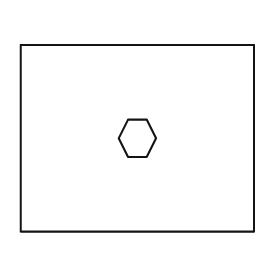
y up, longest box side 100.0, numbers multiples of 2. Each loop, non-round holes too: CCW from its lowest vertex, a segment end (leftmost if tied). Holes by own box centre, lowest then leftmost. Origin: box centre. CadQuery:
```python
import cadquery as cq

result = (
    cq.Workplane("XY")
    .moveTo(-50.0, -40.0)
    .lineTo(50.0, -40.0)
    .lineTo(50.0, 40.0)
    .lineTo(-50.0, 40.0)
    .close()
    .moveTo(-4.0, -8.0)
    .lineTo(4.0, -8.0)
    .lineTo(8.0, 0.0)
    .lineTo(4.0, 8.0)
    .lineTo(-4.0, 8.0)
    .lineTo(-8.0, 0.0)
    .close()
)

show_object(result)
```